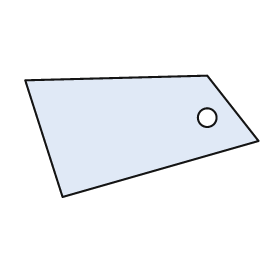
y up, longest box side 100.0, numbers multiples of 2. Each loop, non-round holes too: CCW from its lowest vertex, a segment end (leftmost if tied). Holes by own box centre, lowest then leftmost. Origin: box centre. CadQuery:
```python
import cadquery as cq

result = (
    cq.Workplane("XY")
    .moveTo(-34.0, -26.0)
    .lineTo(50.0, -2.0)
    .lineTo(28.0, 26.0)
    .lineTo(-50.0, 24.0)
    .close()
    .moveTo(28.0, 8.0)
    .circle(4.0)
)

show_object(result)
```